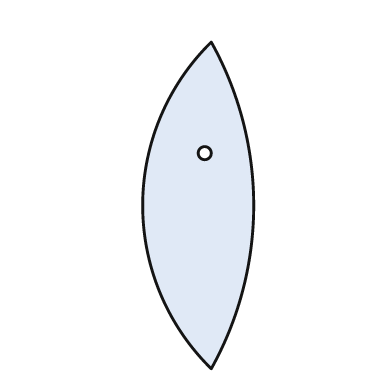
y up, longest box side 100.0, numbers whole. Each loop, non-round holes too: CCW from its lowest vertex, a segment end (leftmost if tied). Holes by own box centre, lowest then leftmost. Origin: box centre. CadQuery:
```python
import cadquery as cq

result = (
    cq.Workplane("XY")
    .moveTo(4.0, -50.0)
    .threePointArc((17.0, 0.0), (4.0, 50.0))
    .threePointArc((-17.0, 0.0), (4.0, -50.0))
    .close()
    .moveTo(2.0, 16.0)
    .circle(2.0)
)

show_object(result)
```